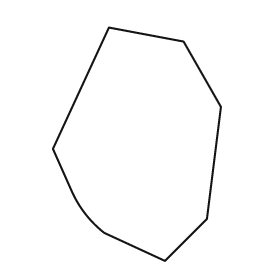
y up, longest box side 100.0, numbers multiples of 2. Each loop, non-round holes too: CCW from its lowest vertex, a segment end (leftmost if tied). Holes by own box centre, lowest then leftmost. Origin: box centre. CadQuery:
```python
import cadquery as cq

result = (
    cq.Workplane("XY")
    .moveTo(12.0, -50.0)
    .lineTo(30.0, -32.0)
    .lineTo(36.0, 16.0)
    .lineTo(20.0, 44.0)
    .lineTo(-12.0, 50.0)
    .lineTo(-36.0, -2.0)
    .lineTo(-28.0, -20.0)
    .threePointArc((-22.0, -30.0), (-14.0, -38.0))
    .close()
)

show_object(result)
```